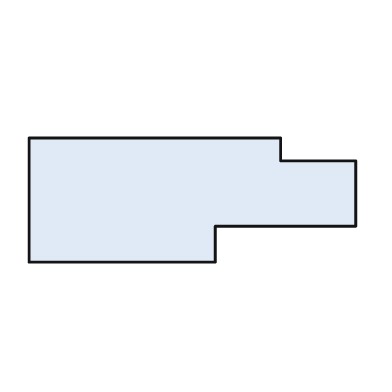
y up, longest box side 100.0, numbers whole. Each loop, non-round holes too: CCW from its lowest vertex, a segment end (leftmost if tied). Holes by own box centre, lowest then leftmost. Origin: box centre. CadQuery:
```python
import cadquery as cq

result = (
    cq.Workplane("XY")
    .moveTo(-50.0, -19.0)
    .lineTo(7.0, -19.0)
    .lineTo(7.0, -8.0)
    .lineTo(50.0, -8.0)
    .lineTo(50.0, 12.0)
    .lineTo(27.0, 12.0)
    .lineTo(27.0, 19.0)
    .lineTo(-50.0, 19.0)
    .close()
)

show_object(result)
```